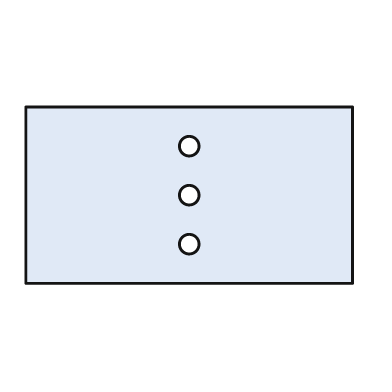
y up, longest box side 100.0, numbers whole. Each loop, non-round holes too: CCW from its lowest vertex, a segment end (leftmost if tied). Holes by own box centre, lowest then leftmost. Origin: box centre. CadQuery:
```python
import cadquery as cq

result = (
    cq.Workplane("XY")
    .moveTo(-50.0, -27.0)
    .lineTo(50.0, -27.0)
    .lineTo(50.0, 27.0)
    .lineTo(-50.0, 27.0)
    .close()
    .moveTo(0.0, -15.0)
    .circle(3.0)
    .moveTo(0.0, 0.0)
    .circle(3.0)
    .moveTo(0.0, 15.0)
    .circle(3.0)
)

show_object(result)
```